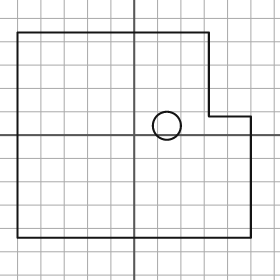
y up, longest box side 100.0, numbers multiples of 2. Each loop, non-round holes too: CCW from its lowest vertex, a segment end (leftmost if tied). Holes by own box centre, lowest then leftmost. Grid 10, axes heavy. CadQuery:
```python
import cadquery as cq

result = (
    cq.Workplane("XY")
    .moveTo(-50.0, -44.0)
    .lineTo(50.0, -44.0)
    .lineTo(50.0, 8.0)
    .lineTo(32.0, 8.0)
    .lineTo(32.0, 44.0)
    .lineTo(-50.0, 44.0)
    .close()
    .moveTo(14.0, 4.0)
    .circle(6.0)
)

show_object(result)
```